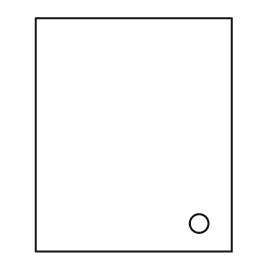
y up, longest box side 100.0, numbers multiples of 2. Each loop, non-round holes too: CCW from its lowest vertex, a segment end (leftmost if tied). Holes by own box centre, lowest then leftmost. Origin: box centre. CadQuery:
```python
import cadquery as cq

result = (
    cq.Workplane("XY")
    .moveTo(-42.0, -50.0)
    .lineTo(42.0, -50.0)
    .lineTo(42.0, 50.0)
    .lineTo(-42.0, 50.0)
    .close()
    .moveTo(28.0, -38.0)
    .circle(4.0)
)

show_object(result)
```